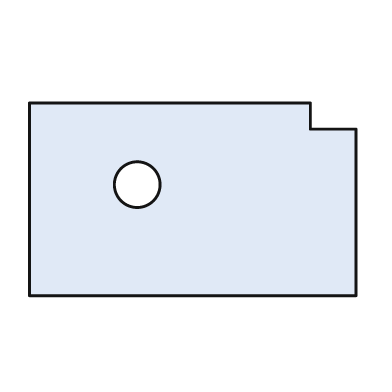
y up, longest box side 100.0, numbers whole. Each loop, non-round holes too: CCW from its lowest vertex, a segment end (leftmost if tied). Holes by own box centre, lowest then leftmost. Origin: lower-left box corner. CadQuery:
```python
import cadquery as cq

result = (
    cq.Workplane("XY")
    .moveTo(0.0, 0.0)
    .lineTo(100.0, 0.0)
    .lineTo(100.0, 51.0)
    .lineTo(86.0, 51.0)
    .lineTo(86.0, 59.0)
    .lineTo(0.0, 59.0)
    .close()
    .moveTo(33.0, 34.0)
    .circle(7.0)
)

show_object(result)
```